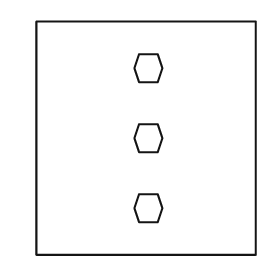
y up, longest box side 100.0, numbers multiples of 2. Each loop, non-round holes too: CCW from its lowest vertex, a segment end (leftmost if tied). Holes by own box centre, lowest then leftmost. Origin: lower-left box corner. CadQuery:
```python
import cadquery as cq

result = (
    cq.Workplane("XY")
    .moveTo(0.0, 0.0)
    .lineTo(94.0, 0.0)
    .lineTo(94.0, 100.0)
    .lineTo(0.0, 100.0)
    .close()
    .moveTo(44.0, 14.0)
    .lineTo(52.0, 14.0)
    .lineTo(54.0, 20.0)
    .lineTo(52.0, 26.0)
    .lineTo(44.0, 26.0)
    .lineTo(42.0, 20.0)
    .close()
    .moveTo(44.0, 44.0)
    .lineTo(52.0, 44.0)
    .lineTo(54.0, 50.0)
    .lineTo(52.0, 56.0)
    .lineTo(44.0, 56.0)
    .lineTo(42.0, 50.0)
    .close()
    .moveTo(44.0, 74.0)
    .lineTo(52.0, 74.0)
    .lineTo(54.0, 80.0)
    .lineTo(52.0, 86.0)
    .lineTo(44.0, 86.0)
    .lineTo(42.0, 80.0)
    .close()
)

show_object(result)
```